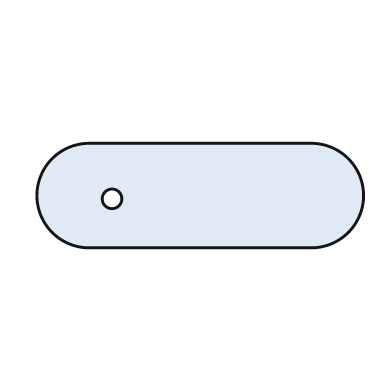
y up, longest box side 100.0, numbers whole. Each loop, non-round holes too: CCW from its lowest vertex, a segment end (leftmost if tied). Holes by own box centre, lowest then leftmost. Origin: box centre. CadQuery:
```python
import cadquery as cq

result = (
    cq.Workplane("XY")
    .moveTo(-34.0, -16.0)
    .lineTo(34.0, -16.0)
    .threePointArc((50.0, 0.0), (34.0, 16.0))
    .lineTo(-34.0, 16.0)
    .threePointArc((-50.0, 0.0), (-34.0, -16.0))
    .close()
    .moveTo(-27.0, -1.0)
    .circle(3.0)
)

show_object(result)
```